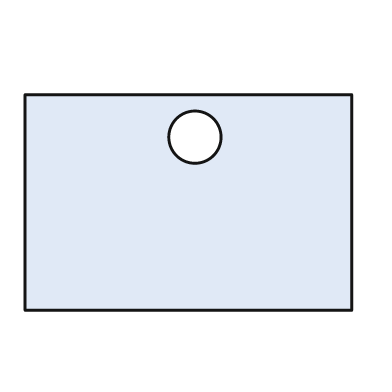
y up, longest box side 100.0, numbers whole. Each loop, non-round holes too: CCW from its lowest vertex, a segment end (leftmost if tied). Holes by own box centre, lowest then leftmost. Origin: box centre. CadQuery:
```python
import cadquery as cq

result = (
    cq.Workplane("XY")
    .moveTo(-50.0, -33.0)
    .lineTo(50.0, -33.0)
    .lineTo(50.0, 33.0)
    .lineTo(-50.0, 33.0)
    .close()
    .moveTo(2.0, 20.0)
    .circle(8.0)
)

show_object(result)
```